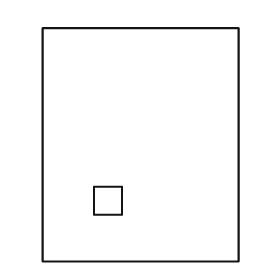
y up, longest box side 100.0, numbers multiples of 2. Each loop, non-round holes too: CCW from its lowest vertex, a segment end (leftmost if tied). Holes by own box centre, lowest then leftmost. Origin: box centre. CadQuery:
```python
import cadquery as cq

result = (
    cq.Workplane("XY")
    .moveTo(-42.0, -50.0)
    .lineTo(42.0, -50.0)
    .lineTo(42.0, 50.0)
    .lineTo(-42.0, 50.0)
    .close()
    .moveTo(-20.0, -30.0)
    .lineTo(-8.0, -30.0)
    .lineTo(-8.0, -18.0)
    .lineTo(-20.0, -18.0)
    .close()
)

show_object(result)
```